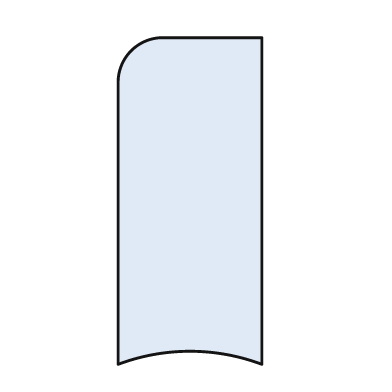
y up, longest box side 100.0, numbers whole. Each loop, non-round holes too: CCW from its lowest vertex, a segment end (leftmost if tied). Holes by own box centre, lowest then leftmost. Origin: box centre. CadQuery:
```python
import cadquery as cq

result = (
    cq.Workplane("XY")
    .moveTo(-22.0, -50.0)
    .threePointArc((0.0, -46.0), (22.0, -50.0))
    .lineTo(22.0, 50.0)
    .lineTo(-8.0, 50.0)
    .threePointArc((-18.0, 46.0), (-22.0, 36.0))
    .close()
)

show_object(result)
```